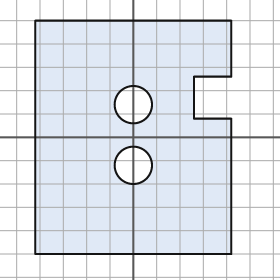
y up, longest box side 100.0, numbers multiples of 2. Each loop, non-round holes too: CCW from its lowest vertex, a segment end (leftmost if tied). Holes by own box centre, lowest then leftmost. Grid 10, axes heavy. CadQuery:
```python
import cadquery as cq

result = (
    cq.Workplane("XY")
    .moveTo(-42.0, -50.0)
    .lineTo(42.0, -50.0)
    .lineTo(42.0, 8.0)
    .lineTo(26.0, 8.0)
    .lineTo(26.0, 26.0)
    .lineTo(42.0, 26.0)
    .lineTo(42.0, 50.0)
    .lineTo(-42.0, 50.0)
    .close()
    .moveTo(0.0, -12.0)
    .circle(8.0)
    .moveTo(0.0, 14.0)
    .circle(8.0)
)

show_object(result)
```